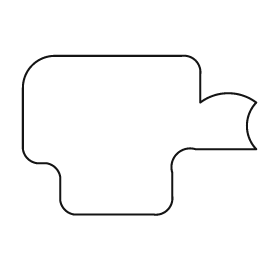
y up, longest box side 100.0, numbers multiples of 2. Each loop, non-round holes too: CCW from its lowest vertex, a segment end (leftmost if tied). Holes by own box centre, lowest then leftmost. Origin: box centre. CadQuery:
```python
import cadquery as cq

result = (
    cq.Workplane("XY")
    .moveTo(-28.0, -34.0)
    .lineTo(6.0, -34.0)
    .threePointArc((12.0, -32.0), (14.0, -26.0))
    .lineTo(14.0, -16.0)
    .threePointArc((16.0, -8.0), (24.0, -6.0))
    .lineTo(50.0, -6.0)
    .threePointArc((46.0, 4.0), (50.0, 14.0))
    .threePointArc((38.0, 18.0), (26.0, 14.0))
    .lineTo(26.0, 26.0)
    .threePointArc((24.0, 32.0), (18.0, 34.0))
    .lineTo(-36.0, 34.0)
    .threePointArc((-46.0, 30.0), (-50.0, 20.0))
    .lineTo(-50.0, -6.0)
    .threePointArc((-48.0, -10.0), (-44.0, -12.0))
    .lineTo(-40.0, -12.0)
    .threePointArc((-36.0, -14.0), (-34.0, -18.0))
    .lineTo(-34.0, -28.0)
    .threePointArc((-32.0, -32.0), (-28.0, -34.0))
    .close()
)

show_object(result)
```